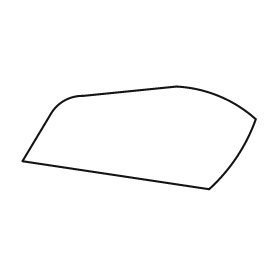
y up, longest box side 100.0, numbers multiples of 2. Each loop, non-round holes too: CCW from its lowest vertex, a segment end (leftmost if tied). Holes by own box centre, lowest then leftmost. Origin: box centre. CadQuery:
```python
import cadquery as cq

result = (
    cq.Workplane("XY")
    .moveTo(30.0, -22.0)
    .threePointArc((42.0, -8.0), (50.0, 8.0))
    .threePointArc((34.0, 18.0), (16.0, 22.0))
    .lineTo(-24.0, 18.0)
    .threePointArc((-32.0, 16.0), (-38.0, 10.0))
    .lineTo(-50.0, -10.0)
    .close()
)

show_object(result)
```